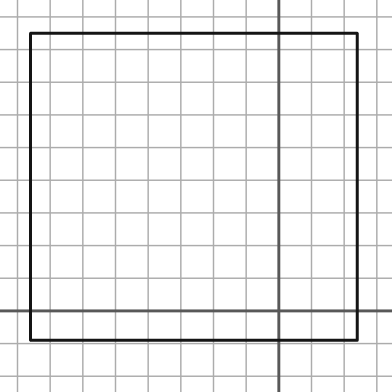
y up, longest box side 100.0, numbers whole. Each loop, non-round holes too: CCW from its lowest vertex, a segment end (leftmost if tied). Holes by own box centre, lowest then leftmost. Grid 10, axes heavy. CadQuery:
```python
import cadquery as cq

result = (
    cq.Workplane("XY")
    .moveTo(-76.0, -9.0)
    .lineTo(24.0, -9.0)
    .lineTo(24.0, 85.0)
    .lineTo(-76.0, 85.0)
    .close()
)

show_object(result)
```